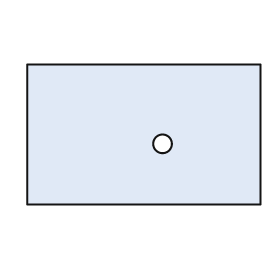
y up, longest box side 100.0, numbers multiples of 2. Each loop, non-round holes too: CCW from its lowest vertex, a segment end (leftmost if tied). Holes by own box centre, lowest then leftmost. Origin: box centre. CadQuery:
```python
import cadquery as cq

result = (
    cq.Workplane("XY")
    .moveTo(-50.0, -30.0)
    .lineTo(50.0, -30.0)
    .lineTo(50.0, 30.0)
    .lineTo(-50.0, 30.0)
    .close()
    .moveTo(8.0, -4.0)
    .circle(4.0)
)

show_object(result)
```